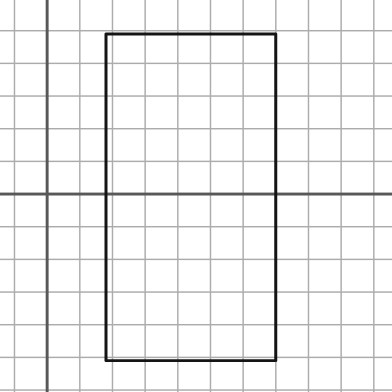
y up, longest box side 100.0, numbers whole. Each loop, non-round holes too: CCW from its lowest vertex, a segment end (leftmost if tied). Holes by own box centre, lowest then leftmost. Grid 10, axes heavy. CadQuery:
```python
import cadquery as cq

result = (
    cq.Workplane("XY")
    .moveTo(18.0, -51.0)
    .lineTo(70.0, -51.0)
    .lineTo(70.0, 49.0)
    .lineTo(18.0, 49.0)
    .close()
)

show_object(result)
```